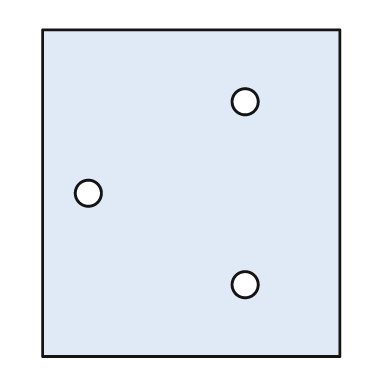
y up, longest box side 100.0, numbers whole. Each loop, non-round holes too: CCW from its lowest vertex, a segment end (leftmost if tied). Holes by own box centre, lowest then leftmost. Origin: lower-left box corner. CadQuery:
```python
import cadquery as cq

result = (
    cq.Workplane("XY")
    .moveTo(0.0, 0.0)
    .lineTo(91.0, 0.0)
    .lineTo(91.0, 100.0)
    .lineTo(0.0, 100.0)
    .close()
    .moveTo(62.0, 22.0)
    .circle(4.0)
    .moveTo(14.0, 50.0)
    .circle(4.0)
    .moveTo(62.0, 78.0)
    .circle(4.0)
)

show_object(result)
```